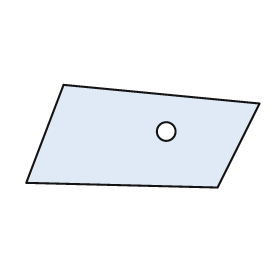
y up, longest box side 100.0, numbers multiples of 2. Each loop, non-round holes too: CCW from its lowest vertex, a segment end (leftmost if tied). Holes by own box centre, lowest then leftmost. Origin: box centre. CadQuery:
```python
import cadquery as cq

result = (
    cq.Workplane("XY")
    .moveTo(32.0, -22.0)
    .lineTo(50.0, 14.0)
    .lineTo(-34.0, 22.0)
    .lineTo(-50.0, -20.0)
    .close()
    .moveTo(10.0, 2.0)
    .circle(4.0)
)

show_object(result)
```